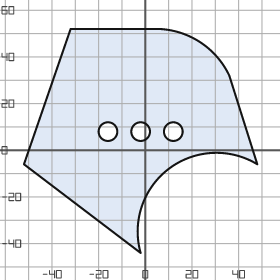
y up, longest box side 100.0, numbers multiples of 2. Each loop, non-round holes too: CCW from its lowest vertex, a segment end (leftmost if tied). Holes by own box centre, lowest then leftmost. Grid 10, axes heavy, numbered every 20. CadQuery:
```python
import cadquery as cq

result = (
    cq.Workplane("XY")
    .moveTo(-2.0, -44.0)
    .threePointArc((10.0, -8.0), (48.0, -6.0))
    .lineTo(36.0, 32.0)
    .threePointArc((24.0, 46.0), (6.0, 52.0))
    .lineTo(-32.0, 52.0)
    .lineTo(-52.0, -6.0)
    .close()
    .moveTo(-16.0, 8.0)
    .circle(4.0)
    .moveTo(-2.0, 8.0)
    .circle(4.0)
    .moveTo(12.0, 8.0)
    .circle(4.0)
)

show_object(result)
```